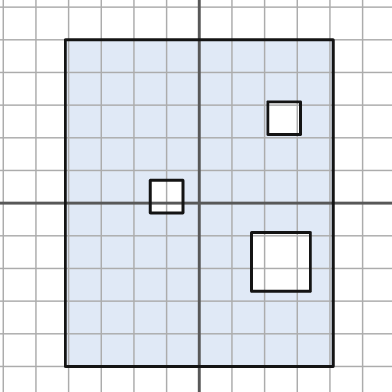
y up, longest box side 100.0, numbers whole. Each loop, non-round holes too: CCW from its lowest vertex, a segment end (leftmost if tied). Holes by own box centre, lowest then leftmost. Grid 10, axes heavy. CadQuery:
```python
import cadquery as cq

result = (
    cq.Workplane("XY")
    .moveTo(-41.0, -50.0)
    .lineTo(41.0, -50.0)
    .lineTo(41.0, 50.0)
    .lineTo(-41.0, 50.0)
    .close()
    .moveTo(16.0, -27.0)
    .lineTo(34.0, -27.0)
    .lineTo(34.0, -9.0)
    .lineTo(16.0, -9.0)
    .close()
    .moveTo(-15.0, -3.0)
    .lineTo(-5.0, -3.0)
    .lineTo(-5.0, 7.0)
    .lineTo(-15.0, 7.0)
    .close()
    .moveTo(21.0, 21.0)
    .lineTo(31.0, 21.0)
    .lineTo(31.0, 31.0)
    .lineTo(21.0, 31.0)
    .close()
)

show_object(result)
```